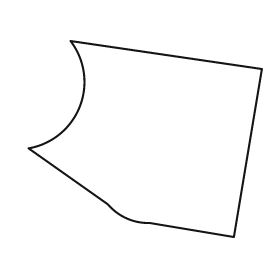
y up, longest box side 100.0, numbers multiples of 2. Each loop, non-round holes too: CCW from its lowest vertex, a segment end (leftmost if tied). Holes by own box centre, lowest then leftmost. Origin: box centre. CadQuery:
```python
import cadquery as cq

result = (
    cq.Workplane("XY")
    .moveTo(38.0, -42.0)
    .lineTo(50.0, 30.0)
    .lineTo(-32.0, 42.0)
    .threePointArc((-28.0, 14.0), (-50.0, -4.0))
    .lineTo(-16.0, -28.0)
    .threePointArc((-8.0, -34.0), (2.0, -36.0))
    .close()
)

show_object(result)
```